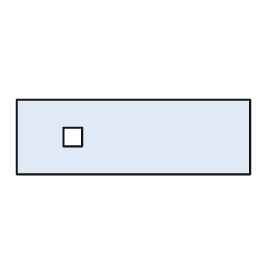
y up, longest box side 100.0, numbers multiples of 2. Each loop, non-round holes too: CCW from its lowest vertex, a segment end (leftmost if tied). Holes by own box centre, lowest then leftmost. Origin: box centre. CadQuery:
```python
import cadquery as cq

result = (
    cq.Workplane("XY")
    .moveTo(-50.0, -16.0)
    .lineTo(50.0, -16.0)
    .lineTo(50.0, 16.0)
    .lineTo(-50.0, 16.0)
    .close()
    .moveTo(-30.0, -4.0)
    .lineTo(-22.0, -4.0)
    .lineTo(-22.0, 4.0)
    .lineTo(-30.0, 4.0)
    .close()
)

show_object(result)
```